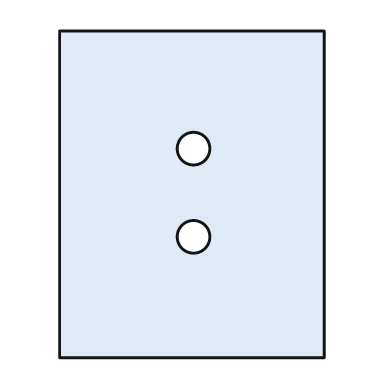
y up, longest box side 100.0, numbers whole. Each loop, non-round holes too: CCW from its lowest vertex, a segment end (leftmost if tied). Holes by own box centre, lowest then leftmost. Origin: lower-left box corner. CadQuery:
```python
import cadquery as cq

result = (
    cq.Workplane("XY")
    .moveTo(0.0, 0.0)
    .lineTo(81.0, 0.0)
    .lineTo(81.0, 100.0)
    .lineTo(0.0, 100.0)
    .close()
    .moveTo(41.0, 37.0)
    .circle(5.0)
    .moveTo(41.0, 64.0)
    .circle(5.0)
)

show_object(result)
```